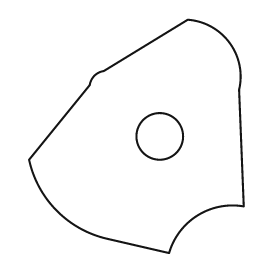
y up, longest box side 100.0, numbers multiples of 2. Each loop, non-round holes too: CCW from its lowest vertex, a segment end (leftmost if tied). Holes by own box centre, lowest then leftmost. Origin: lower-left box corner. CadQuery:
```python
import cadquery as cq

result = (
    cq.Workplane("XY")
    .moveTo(60.0, 0.0)
    .threePointArc((72.0, 16.0), (92.0, 20.0))
    .lineTo(90.0, 70.0)
    .threePointArc((86.0, 90.0), (68.0, 100.0))
    .lineTo(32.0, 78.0)
    .threePointArc((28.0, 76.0), (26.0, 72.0))
    .lineTo(0.0, 40.0)
    .threePointArc((12.0, 18.0), (34.0, 6.0))
    .close()
    .moveTo(56.0, 50.0)
    .circle(10.0)
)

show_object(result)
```